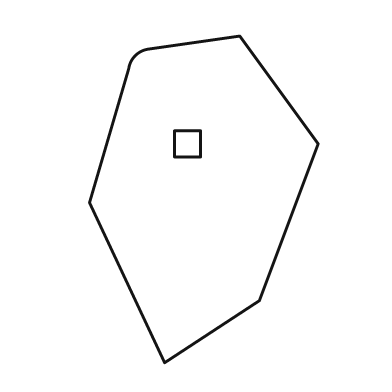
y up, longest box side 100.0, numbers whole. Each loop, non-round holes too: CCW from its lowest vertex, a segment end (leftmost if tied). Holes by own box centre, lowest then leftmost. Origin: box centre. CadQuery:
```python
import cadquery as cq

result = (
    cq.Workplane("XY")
    .moveTo(-12.0, -50.0)
    .lineTo(17.0, -31.0)
    .lineTo(35.0, 17.0)
    .lineTo(11.0, 50.0)
    .lineTo(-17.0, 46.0)
    .threePointArc((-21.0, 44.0), (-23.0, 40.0))
    .lineTo(-35.0, -1.0)
    .close()
    .moveTo(-9.0, 13.0)
    .lineTo(-1.0, 13.0)
    .lineTo(-1.0, 21.0)
    .lineTo(-9.0, 21.0)
    .close()
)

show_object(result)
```